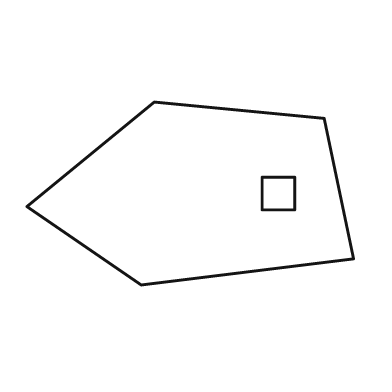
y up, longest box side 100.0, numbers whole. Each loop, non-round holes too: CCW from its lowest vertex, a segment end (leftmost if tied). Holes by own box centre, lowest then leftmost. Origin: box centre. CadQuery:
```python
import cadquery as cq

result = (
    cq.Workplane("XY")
    .moveTo(-15.0, -28.0)
    .lineTo(50.0, -20.0)
    .lineTo(41.0, 23.0)
    .lineTo(-11.0, 28.0)
    .lineTo(-50.0, -4.0)
    .close()
    .moveTo(22.0, -5.0)
    .lineTo(32.0, -5.0)
    .lineTo(32.0, 5.0)
    .lineTo(22.0, 5.0)
    .close()
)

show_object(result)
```